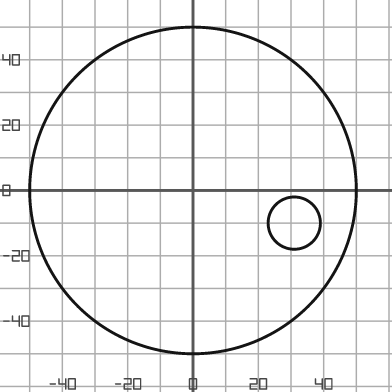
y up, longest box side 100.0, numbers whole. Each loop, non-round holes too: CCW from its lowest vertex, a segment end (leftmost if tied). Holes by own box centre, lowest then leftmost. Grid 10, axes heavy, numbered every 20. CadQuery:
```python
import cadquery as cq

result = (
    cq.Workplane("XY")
    .moveTo(0.0, 0.0)
    .circle(50.0)
    .moveTo(31.0, -10.0)
    .circle(8.0)
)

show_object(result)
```